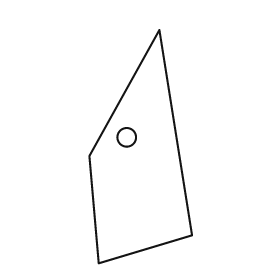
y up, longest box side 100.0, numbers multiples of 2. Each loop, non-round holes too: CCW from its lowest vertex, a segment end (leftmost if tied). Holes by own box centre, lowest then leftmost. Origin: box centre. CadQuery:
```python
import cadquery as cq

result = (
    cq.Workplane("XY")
    .moveTo(-18.0, -50.0)
    .lineTo(22.0, -38.0)
    .lineTo(8.0, 50.0)
    .lineTo(-22.0, -4.0)
    .close()
    .moveTo(-6.0, 4.0)
    .circle(4.0)
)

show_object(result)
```